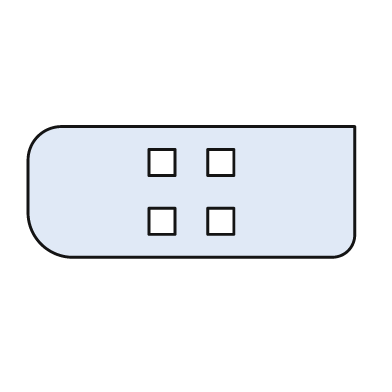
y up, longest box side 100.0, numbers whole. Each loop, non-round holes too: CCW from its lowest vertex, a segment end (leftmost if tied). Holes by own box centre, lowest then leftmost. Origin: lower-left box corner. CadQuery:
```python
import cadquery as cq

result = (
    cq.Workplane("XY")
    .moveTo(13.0, 0.0)
    .lineTo(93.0, 0.0)
    .threePointArc((98.0, 2.0), (100.0, 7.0))
    .lineTo(100.0, 40.0)
    .lineTo(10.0, 40.0)
    .threePointArc((3.0, 37.0), (0.0, 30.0))
    .lineTo(0.0, 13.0)
    .threePointArc((4.0, 4.0), (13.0, 0.0))
    .close()
    .moveTo(37.0, 7.0)
    .lineTo(45.0, 7.0)
    .lineTo(45.0, 15.0)
    .lineTo(37.0, 15.0)
    .close()
    .moveTo(55.0, 7.0)
    .lineTo(63.0, 7.0)
    .lineTo(63.0, 15.0)
    .lineTo(55.0, 15.0)
    .close()
    .moveTo(37.0, 25.0)
    .lineTo(45.0, 25.0)
    .lineTo(45.0, 33.0)
    .lineTo(37.0, 33.0)
    .close()
    .moveTo(55.0, 25.0)
    .lineTo(63.0, 25.0)
    .lineTo(63.0, 33.0)
    .lineTo(55.0, 33.0)
    .close()
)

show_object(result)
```